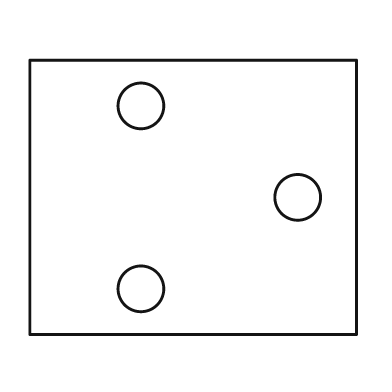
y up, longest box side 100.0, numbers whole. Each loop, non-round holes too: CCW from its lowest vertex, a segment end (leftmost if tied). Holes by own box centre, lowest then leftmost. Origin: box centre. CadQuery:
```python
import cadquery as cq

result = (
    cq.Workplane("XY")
    .moveTo(-50.0, -42.0)
    .lineTo(50.0, -42.0)
    .lineTo(50.0, 42.0)
    .lineTo(-50.0, 42.0)
    .close()
    .moveTo(-16.0, -28.0)
    .circle(7.0)
    .moveTo(32.0, 0.0)
    .circle(7.0)
    .moveTo(-16.0, 28.0)
    .circle(7.0)
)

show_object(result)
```